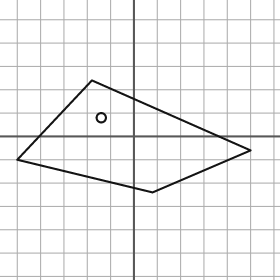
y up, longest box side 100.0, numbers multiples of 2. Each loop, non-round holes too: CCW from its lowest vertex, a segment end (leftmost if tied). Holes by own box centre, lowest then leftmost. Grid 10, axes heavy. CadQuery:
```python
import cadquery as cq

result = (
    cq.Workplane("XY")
    .moveTo(8.0, -24.0)
    .lineTo(50.0, -6.0)
    .lineTo(-18.0, 24.0)
    .lineTo(-50.0, -10.0)
    .close()
    .moveTo(-14.0, 8.0)
    .circle(2.0)
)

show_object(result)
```